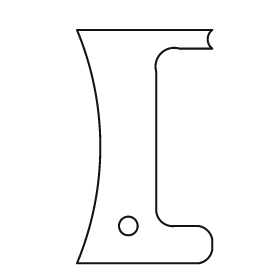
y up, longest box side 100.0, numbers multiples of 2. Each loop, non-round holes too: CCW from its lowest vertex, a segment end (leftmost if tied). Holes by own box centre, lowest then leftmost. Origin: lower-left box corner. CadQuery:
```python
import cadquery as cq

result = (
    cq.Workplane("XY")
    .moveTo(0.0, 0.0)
    .lineTo(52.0, 0.0)
    .threePointArc((56.0, 2.0), (58.0, 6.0))
    .lineTo(58.0, 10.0)
    .threePointArc((56.0, 14.0), (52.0, 16.0))
    .lineTo(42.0, 16.0)
    .threePointArc((36.0, 18.0), (34.0, 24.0))
    .lineTo(34.0, 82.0)
    .threePointArc((36.0, 90.0), (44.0, 92.0))
    .lineTo(58.0, 92.0)
    .threePointArc((56.0, 96.0), (58.0, 100.0))
    .lineTo(0.0, 100.0)
    .threePointArc((10.0, 50.0), (0.0, 0.0))
    .close()
    .moveTo(22.0, 16.0)
    .circle(4.0)
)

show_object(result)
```